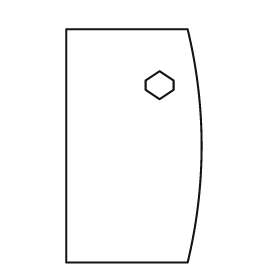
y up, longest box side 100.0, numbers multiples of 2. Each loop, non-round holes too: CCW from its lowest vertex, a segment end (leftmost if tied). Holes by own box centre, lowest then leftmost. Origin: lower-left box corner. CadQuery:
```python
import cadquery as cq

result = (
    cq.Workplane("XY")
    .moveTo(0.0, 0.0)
    .lineTo(52.0, 0.0)
    .threePointArc((58.0, 50.0), (52.0, 100.0))
    .lineTo(0.0, 100.0)
    .close()
    .moveTo(40.0, 70.0)
    .lineTo(46.0, 74.0)
    .lineTo(46.0, 78.0)
    .lineTo(40.0, 82.0)
    .lineTo(34.0, 78.0)
    .lineTo(34.0, 74.0)
    .close()
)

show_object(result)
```